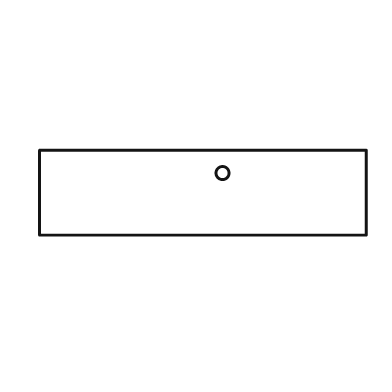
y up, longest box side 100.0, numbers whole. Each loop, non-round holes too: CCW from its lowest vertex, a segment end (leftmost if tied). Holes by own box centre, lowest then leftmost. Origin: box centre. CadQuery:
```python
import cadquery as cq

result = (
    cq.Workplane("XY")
    .moveTo(-50.0, -13.0)
    .lineTo(50.0, -13.0)
    .lineTo(50.0, 13.0)
    .lineTo(-50.0, 13.0)
    .close()
    .moveTo(6.0, 6.0)
    .circle(2.0)
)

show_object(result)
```